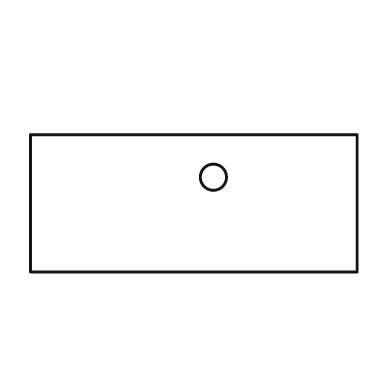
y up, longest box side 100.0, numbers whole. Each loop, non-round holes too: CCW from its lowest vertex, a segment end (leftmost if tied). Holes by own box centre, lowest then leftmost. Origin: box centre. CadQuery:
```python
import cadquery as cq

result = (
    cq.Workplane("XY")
    .moveTo(-50.0, -21.0)
    .lineTo(50.0, -21.0)
    .lineTo(50.0, 21.0)
    .lineTo(-50.0, 21.0)
    .close()
    .moveTo(6.0, 8.0)
    .circle(4.0)
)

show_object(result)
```